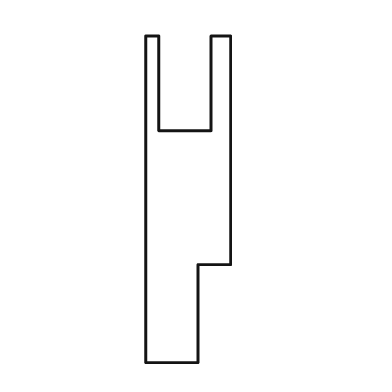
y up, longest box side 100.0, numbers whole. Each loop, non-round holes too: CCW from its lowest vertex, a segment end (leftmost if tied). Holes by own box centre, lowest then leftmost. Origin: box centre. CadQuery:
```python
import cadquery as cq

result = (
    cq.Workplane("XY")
    .moveTo(-13.0, -50.0)
    .lineTo(3.0, -50.0)
    .lineTo(3.0, -20.0)
    .lineTo(13.0, -20.0)
    .lineTo(13.0, 50.0)
    .lineTo(7.0, 50.0)
    .lineTo(7.0, 21.0)
    .lineTo(-9.0, 21.0)
    .lineTo(-9.0, 50.0)
    .lineTo(-13.0, 50.0)
    .close()
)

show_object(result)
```